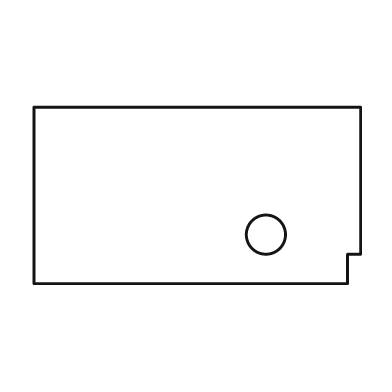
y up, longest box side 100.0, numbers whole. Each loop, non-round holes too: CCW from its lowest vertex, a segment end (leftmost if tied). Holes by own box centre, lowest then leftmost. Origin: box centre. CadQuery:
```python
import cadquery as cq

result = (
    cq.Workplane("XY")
    .moveTo(-50.0, -27.0)
    .lineTo(46.0, -27.0)
    .lineTo(46.0, -18.0)
    .lineTo(50.0, -18.0)
    .lineTo(50.0, 27.0)
    .lineTo(-50.0, 27.0)
    .close()
    .moveTo(21.0, -12.0)
    .circle(6.0)
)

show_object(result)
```